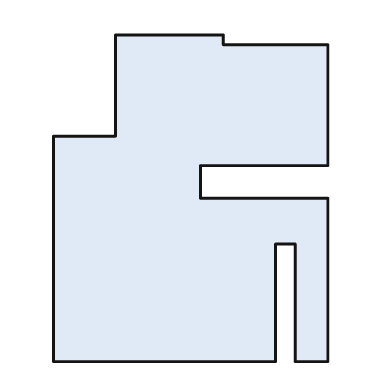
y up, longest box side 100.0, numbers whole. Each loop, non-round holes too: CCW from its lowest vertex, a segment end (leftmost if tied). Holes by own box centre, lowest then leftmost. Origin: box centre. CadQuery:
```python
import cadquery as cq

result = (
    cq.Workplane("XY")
    .moveTo(-42.0, -50.0)
    .lineTo(26.0, -50.0)
    .lineTo(26.0, -14.0)
    .lineTo(32.0, -14.0)
    .lineTo(32.0, -50.0)
    .lineTo(42.0, -50.0)
    .lineTo(42.0, 0.0)
    .lineTo(3.0, 0.0)
    .lineTo(3.0, 10.0)
    .lineTo(42.0, 10.0)
    .lineTo(42.0, 47.0)
    .lineTo(10.0, 47.0)
    .lineTo(10.0, 50.0)
    .lineTo(-23.0, 50.0)
    .lineTo(-23.0, 19.0)
    .lineTo(-42.0, 19.0)
    .close()
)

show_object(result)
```